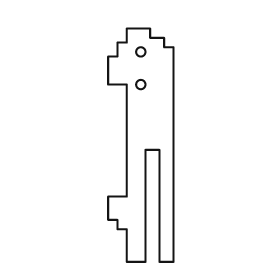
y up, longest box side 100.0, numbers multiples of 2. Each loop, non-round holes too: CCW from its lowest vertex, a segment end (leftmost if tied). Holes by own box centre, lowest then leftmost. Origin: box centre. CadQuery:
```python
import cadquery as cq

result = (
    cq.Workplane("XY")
    .moveTo(-6.0, -50.0)
    .lineTo(2.0, -50.0)
    .lineTo(2.0, -2.0)
    .lineTo(8.0, -2.0)
    .lineTo(8.0, -50.0)
    .lineTo(14.0, -50.0)
    .lineTo(14.0, 42.0)
    .lineTo(10.0, 42.0)
    .lineTo(10.0, 46.0)
    .lineTo(4.0, 46.0)
    .lineTo(4.0, 50.0)
    .lineTo(-6.0, 50.0)
    .lineTo(-6.0, 44.0)
    .lineTo(-10.0, 44.0)
    .lineTo(-10.0, 38.0)
    .lineTo(-14.0, 38.0)
    .lineTo(-14.0, 26.0)
    .lineTo(-6.0, 26.0)
    .lineTo(-6.0, -22.0)
    .lineTo(-14.0, -22.0)
    .lineTo(-14.0, -32.0)
    .lineTo(-10.0, -32.0)
    .lineTo(-10.0, -36.0)
    .lineTo(-6.0, -36.0)
    .close()
    .moveTo(0.0, 26.0)
    .circle(2.0)
    .moveTo(0.0, 40.0)
    .circle(2.0)
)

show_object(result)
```